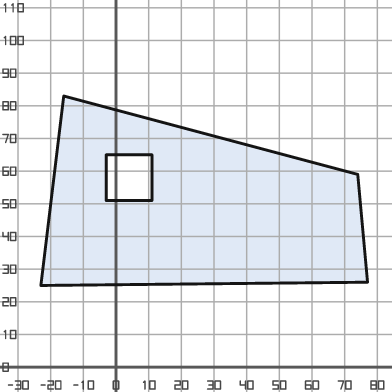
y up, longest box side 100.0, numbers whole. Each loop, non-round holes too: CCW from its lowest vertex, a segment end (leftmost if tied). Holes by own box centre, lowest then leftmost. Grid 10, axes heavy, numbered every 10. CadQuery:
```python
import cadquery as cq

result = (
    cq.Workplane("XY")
    .moveTo(-23.0, 25.0)
    .lineTo(77.0, 26.0)
    .lineTo(74.0, 59.0)
    .lineTo(-16.0, 83.0)
    .close()
    .moveTo(-3.0, 51.0)
    .lineTo(11.0, 51.0)
    .lineTo(11.0, 65.0)
    .lineTo(-3.0, 65.0)
    .close()
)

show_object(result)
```